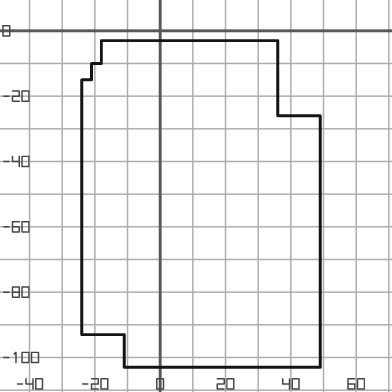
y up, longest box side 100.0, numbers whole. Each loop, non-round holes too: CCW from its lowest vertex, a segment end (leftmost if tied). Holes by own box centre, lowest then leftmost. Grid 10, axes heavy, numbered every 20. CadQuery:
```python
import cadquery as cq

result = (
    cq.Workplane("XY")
    .moveTo(-11.0, -103.0)
    .lineTo(49.0, -103.0)
    .lineTo(49.0, -26.0)
    .lineTo(36.0, -26.0)
    .lineTo(36.0, -3.0)
    .lineTo(-18.0, -3.0)
    .lineTo(-18.0, -10.0)
    .lineTo(-21.0, -10.0)
    .lineTo(-21.0, -15.0)
    .lineTo(-24.0, -15.0)
    .lineTo(-24.0, -93.0)
    .lineTo(-11.0, -93.0)
    .close()
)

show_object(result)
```